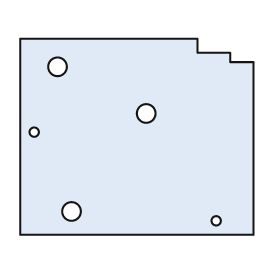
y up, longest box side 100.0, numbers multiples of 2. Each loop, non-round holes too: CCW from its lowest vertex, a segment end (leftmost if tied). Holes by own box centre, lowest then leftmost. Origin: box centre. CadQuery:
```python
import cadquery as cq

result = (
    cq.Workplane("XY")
    .moveTo(-50.0, -42.0)
    .lineTo(50.0, -42.0)
    .lineTo(50.0, 32.0)
    .lineTo(40.0, 32.0)
    .lineTo(40.0, 36.0)
    .lineTo(26.0, 36.0)
    .lineTo(26.0, 42.0)
    .lineTo(-50.0, 42.0)
    .close()
    .moveTo(34.0, -36.0)
    .circle(2.0)
    .moveTo(-28.0, -32.0)
    .circle(4.0)
    .moveTo(-44.0, 2.0)
    .circle(2.0)
    .moveTo(4.0, 10.0)
    .circle(4.0)
    .moveTo(-34.0, 30.0)
    .circle(4.0)
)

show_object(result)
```